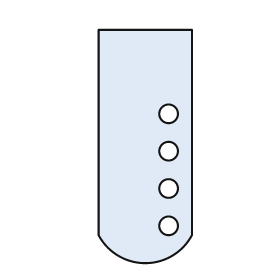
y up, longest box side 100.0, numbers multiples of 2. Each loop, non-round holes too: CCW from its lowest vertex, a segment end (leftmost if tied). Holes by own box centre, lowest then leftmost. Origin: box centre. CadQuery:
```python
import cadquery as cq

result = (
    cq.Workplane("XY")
    .moveTo(-20.0, -38.0)
    .threePointArc((0.0, -50.0), (20.0, -38.0))
    .lineTo(20.0, 50.0)
    .lineTo(-20.0, 50.0)
    .close()
    .moveTo(10.0, -34.0)
    .circle(4.0)
    .moveTo(10.0, -18.0)
    .circle(4.0)
    .moveTo(10.0, -2.0)
    .circle(4.0)
    .moveTo(10.0, 14.0)
    .circle(4.0)
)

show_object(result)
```